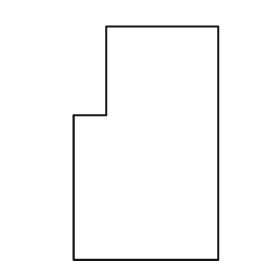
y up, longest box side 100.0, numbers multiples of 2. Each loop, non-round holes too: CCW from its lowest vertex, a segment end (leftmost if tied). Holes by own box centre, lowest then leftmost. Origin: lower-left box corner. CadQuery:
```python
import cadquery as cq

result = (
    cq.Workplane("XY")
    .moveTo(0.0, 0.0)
    .lineTo(62.0, 0.0)
    .lineTo(62.0, 100.0)
    .lineTo(14.0, 100.0)
    .lineTo(14.0, 62.0)
    .lineTo(0.0, 62.0)
    .close()
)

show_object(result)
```